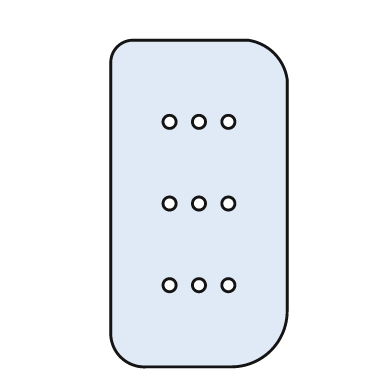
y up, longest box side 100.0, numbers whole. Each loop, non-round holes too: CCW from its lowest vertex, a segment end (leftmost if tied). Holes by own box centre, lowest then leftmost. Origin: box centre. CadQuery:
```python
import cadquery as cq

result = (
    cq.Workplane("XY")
    .moveTo(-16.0, -50.0)
    .lineTo(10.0, -50.0)
    .threePointArc((22.0, -45.0), (27.0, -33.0))
    .lineTo(27.0, 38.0)
    .threePointArc((23.0, 46.0), (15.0, 50.0))
    .lineTo(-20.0, 50.0)
    .threePointArc((-25.0, 48.0), (-27.0, 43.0))
    .lineTo(-27.0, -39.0)
    .threePointArc((-24.0, -47.0), (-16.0, -50.0))
    .close()
    .moveTo(-9.0, -25.0)
    .circle(2.0)
    .moveTo(0.0, -25.0)
    .circle(2.0)
    .moveTo(9.0, -25.0)
    .circle(2.0)
    .moveTo(-9.0, 0.0)
    .circle(2.0)
    .moveTo(0.0, 0.0)
    .circle(2.0)
    .moveTo(9.0, 0.0)
    .circle(2.0)
    .moveTo(-9.0, 25.0)
    .circle(2.0)
    .moveTo(0.0, 25.0)
    .circle(2.0)
    .moveTo(9.0, 25.0)
    .circle(2.0)
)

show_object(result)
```